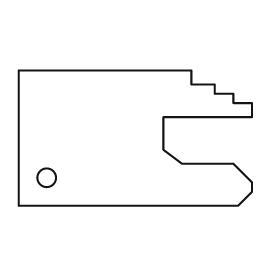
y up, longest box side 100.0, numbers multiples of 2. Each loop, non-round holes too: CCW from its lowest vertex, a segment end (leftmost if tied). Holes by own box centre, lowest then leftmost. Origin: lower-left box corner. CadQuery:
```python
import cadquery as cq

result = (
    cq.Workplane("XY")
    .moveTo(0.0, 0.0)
    .lineTo(94.0, 0.0)
    .lineTo(100.0, 6.0)
    .lineTo(100.0, 10.0)
    .lineTo(92.0, 18.0)
    .lineTo(70.0, 18.0)
    .lineTo(62.0, 24.0)
    .lineTo(62.0, 38.0)
    .lineTo(100.0, 38.0)
    .lineTo(100.0, 44.0)
    .lineTo(92.0, 44.0)
    .lineTo(92.0, 48.0)
    .lineTo(84.0, 48.0)
    .lineTo(84.0, 52.0)
    .lineTo(74.0, 52.0)
    .lineTo(74.0, 58.0)
    .lineTo(0.0, 58.0)
    .close()
    .moveTo(12.0, 12.0)
    .circle(4.0)
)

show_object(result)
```